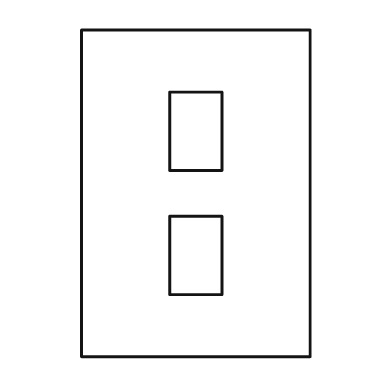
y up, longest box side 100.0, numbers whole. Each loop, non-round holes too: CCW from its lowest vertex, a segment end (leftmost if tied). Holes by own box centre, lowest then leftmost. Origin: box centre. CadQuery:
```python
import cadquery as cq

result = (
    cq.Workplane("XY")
    .moveTo(-35.0, -50.0)
    .lineTo(35.0, -50.0)
    .lineTo(35.0, 50.0)
    .lineTo(-35.0, 50.0)
    .close()
    .moveTo(-8.0, -31.0)
    .lineTo(8.0, -31.0)
    .lineTo(8.0, -7.0)
    .lineTo(-8.0, -7.0)
    .close()
    .moveTo(-8.0, 7.0)
    .lineTo(8.0, 7.0)
    .lineTo(8.0, 31.0)
    .lineTo(-8.0, 31.0)
    .close()
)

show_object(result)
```